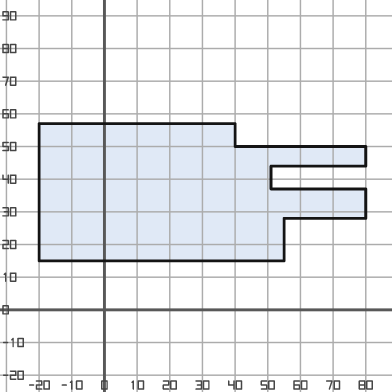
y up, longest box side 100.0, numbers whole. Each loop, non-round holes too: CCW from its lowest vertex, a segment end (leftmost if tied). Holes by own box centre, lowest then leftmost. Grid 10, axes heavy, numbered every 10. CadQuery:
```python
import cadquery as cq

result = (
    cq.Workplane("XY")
    .moveTo(-20.0, 15.0)
    .lineTo(55.0, 15.0)
    .lineTo(55.0, 28.0)
    .lineTo(80.0, 28.0)
    .lineTo(80.0, 37.0)
    .lineTo(51.0, 37.0)
    .lineTo(51.0, 44.0)
    .lineTo(80.0, 44.0)
    .lineTo(80.0, 50.0)
    .lineTo(40.0, 50.0)
    .lineTo(40.0, 57.0)
    .lineTo(-20.0, 57.0)
    .close()
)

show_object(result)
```